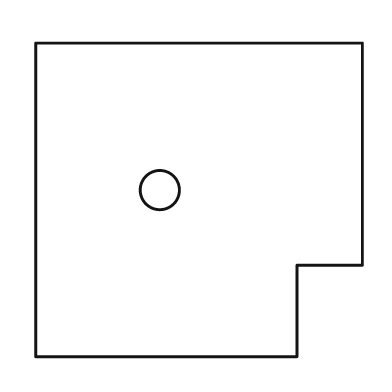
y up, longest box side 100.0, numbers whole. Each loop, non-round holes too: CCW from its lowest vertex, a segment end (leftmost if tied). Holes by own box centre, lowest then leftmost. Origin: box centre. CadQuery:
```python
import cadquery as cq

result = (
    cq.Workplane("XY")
    .moveTo(-50.0, -48.0)
    .lineTo(30.0, -48.0)
    .lineTo(30.0, -20.0)
    .lineTo(50.0, -20.0)
    .lineTo(50.0, 48.0)
    .lineTo(-50.0, 48.0)
    .close()
    .moveTo(-12.0, 3.0)
    .circle(6.0)
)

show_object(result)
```